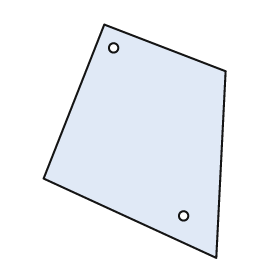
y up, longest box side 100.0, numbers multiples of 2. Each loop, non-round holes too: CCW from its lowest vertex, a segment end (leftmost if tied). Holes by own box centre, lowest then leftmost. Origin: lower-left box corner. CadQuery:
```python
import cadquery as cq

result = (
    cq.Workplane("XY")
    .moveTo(74.0, 0.0)
    .lineTo(78.0, 80.0)
    .lineTo(26.0, 100.0)
    .lineTo(0.0, 34.0)
    .close()
    .moveTo(60.0, 18.0)
    .circle(2.0)
    .moveTo(30.0, 90.0)
    .circle(2.0)
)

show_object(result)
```